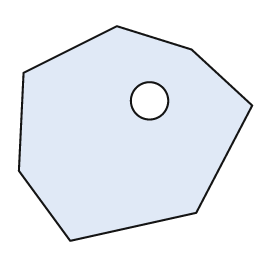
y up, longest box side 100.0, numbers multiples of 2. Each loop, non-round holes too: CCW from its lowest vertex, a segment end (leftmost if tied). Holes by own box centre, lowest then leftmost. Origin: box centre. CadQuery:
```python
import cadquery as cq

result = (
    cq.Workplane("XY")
    .moveTo(-28.0, -46.0)
    .lineTo(26.0, -34.0)
    .lineTo(50.0, 12.0)
    .lineTo(24.0, 36.0)
    .lineTo(-8.0, 46.0)
    .lineTo(-48.0, 26.0)
    .lineTo(-50.0, -16.0)
    .close()
    .moveTo(6.0, 14.0)
    .circle(8.0)
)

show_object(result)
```